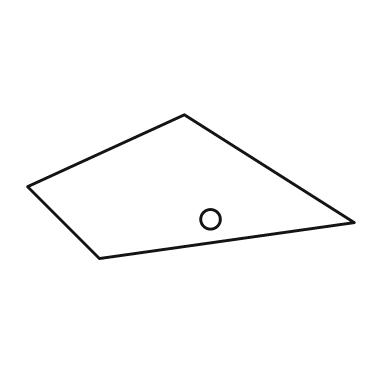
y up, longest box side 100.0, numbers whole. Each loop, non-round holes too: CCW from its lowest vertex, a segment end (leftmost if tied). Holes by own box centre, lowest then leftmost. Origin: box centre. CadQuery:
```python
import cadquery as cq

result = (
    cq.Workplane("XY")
    .moveTo(-28.0, -22.0)
    .lineTo(50.0, -11.0)
    .lineTo(-2.0, 22.0)
    .lineTo(-50.0, 0.0)
    .close()
    .moveTo(6.0, -10.0)
    .circle(3.0)
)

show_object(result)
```